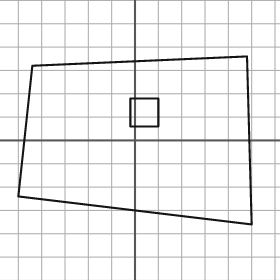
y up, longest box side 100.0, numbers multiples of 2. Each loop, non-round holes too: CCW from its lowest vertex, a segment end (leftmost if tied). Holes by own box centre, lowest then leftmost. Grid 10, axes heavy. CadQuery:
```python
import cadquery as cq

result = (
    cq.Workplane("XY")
    .moveTo(50.0, -36.0)
    .lineTo(48.0, 36.0)
    .lineTo(-44.0, 32.0)
    .lineTo(-50.0, -24.0)
    .close()
    .moveTo(-2.0, 6.0)
    .lineTo(10.0, 6.0)
    .lineTo(10.0, 18.0)
    .lineTo(-2.0, 18.0)
    .close()
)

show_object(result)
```